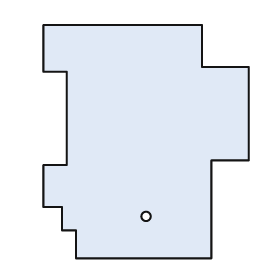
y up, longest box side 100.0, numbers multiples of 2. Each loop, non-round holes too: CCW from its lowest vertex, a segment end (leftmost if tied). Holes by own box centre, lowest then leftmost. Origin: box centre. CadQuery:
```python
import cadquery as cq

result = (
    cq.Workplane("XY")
    .moveTo(-30.0, -50.0)
    .lineTo(28.0, -50.0)
    .lineTo(28.0, -8.0)
    .lineTo(44.0, -8.0)
    .lineTo(44.0, 32.0)
    .lineTo(24.0, 32.0)
    .lineTo(24.0, 50.0)
    .lineTo(-44.0, 50.0)
    .lineTo(-44.0, 30.0)
    .lineTo(-34.0, 30.0)
    .lineTo(-34.0, -10.0)
    .lineTo(-44.0, -10.0)
    .lineTo(-44.0, -28.0)
    .lineTo(-36.0, -28.0)
    .lineTo(-36.0, -38.0)
    .lineTo(-30.0, -38.0)
    .close()
    .moveTo(0.0, -32.0)
    .circle(2.0)
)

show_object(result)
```